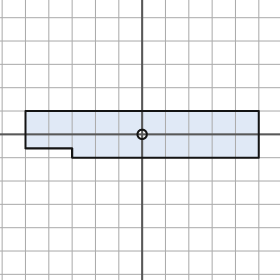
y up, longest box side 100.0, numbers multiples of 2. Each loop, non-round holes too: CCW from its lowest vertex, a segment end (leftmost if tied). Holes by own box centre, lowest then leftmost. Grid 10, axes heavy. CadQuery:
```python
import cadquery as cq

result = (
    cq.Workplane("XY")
    .moveTo(-30.0, -10.0)
    .lineTo(50.0, -10.0)
    .lineTo(50.0, 10.0)
    .lineTo(-50.0, 10.0)
    .lineTo(-50.0, -6.0)
    .lineTo(-30.0, -6.0)
    .close()
    .moveTo(0.0, 0.0)
    .circle(2.0)
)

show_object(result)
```